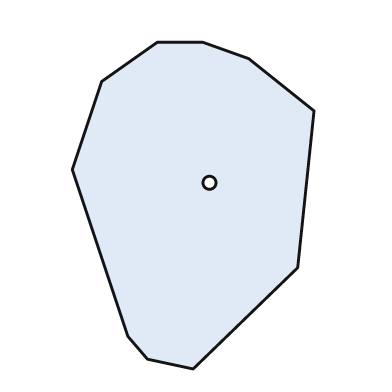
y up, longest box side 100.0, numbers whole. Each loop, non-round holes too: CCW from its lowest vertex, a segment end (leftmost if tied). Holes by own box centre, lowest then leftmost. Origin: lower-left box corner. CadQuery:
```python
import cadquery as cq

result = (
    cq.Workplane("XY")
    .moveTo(37.0, 0.0)
    .lineTo(69.0, 31.0)
    .lineTo(74.0, 79.0)
    .lineTo(54.0, 95.0)
    .lineTo(40.0, 100.0)
    .lineTo(26.0, 100.0)
    .lineTo(9.0, 88.0)
    .lineTo(0.0, 61.0)
    .lineTo(17.0, 10.0)
    .lineTo(23.0, 3.0)
    .close()
    .moveTo(42.0, 57.0)
    .circle(2.0)
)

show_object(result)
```